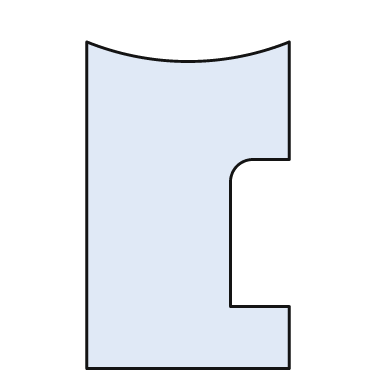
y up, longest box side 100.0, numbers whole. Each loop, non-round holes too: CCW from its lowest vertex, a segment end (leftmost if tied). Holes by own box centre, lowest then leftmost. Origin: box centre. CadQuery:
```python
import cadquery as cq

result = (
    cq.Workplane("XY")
    .moveTo(-31.0, -50.0)
    .lineTo(31.0, -50.0)
    .lineTo(31.0, -31.0)
    .lineTo(13.0, -31.0)
    .lineTo(13.0, 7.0)
    .threePointArc((15.0, 12.0), (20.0, 14.0))
    .lineTo(31.0, 14.0)
    .lineTo(31.0, 50.0)
    .threePointArc((0.0, 44.0), (-31.0, 50.0))
    .close()
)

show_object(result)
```